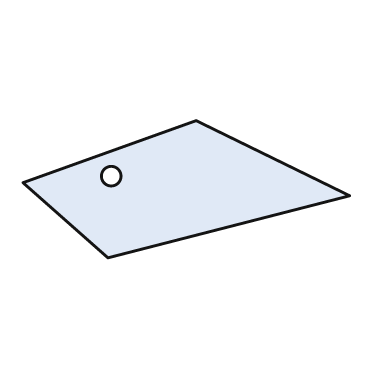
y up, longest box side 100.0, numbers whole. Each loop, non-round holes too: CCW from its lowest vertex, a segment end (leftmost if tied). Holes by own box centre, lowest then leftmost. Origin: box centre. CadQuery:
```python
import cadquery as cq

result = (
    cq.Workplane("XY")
    .moveTo(-24.0, -21.0)
    .lineTo(50.0, -2.0)
    .lineTo(3.0, 21.0)
    .lineTo(-50.0, 2.0)
    .close()
    .moveTo(-23.0, 4.0)
    .circle(3.0)
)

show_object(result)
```